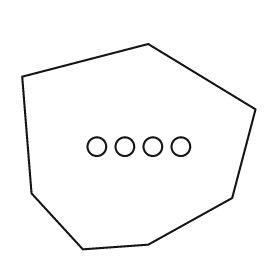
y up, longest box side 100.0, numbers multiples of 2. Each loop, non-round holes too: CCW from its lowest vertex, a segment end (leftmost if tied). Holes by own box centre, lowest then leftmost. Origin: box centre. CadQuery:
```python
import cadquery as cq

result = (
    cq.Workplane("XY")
    .moveTo(-24.0, -44.0)
    .lineTo(4.0, -42.0)
    .lineTo(40.0, -22.0)
    .lineTo(50.0, 16.0)
    .lineTo(4.0, 44.0)
    .lineTo(-50.0, 30.0)
    .lineTo(-46.0, -20.0)
    .close()
    .moveTo(-18.0, 0.0)
    .circle(4.0)
    .moveTo(-6.0, 0.0)
    .circle(4.0)
    .moveTo(6.0, 0.0)
    .circle(4.0)
    .moveTo(18.0, 0.0)
    .circle(4.0)
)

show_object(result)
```